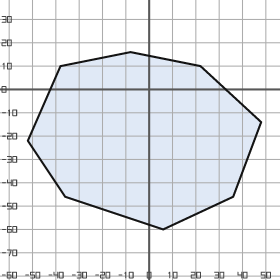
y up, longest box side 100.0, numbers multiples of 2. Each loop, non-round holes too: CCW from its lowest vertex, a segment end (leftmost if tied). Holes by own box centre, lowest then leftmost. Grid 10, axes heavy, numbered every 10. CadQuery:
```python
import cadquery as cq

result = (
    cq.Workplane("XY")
    .moveTo(6.0, -60.0)
    .lineTo(36.0, -46.0)
    .lineTo(48.0, -14.0)
    .lineTo(22.0, 10.0)
    .lineTo(-8.0, 16.0)
    .lineTo(-38.0, 10.0)
    .lineTo(-52.0, -22.0)
    .lineTo(-36.0, -46.0)
    .close()
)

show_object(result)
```